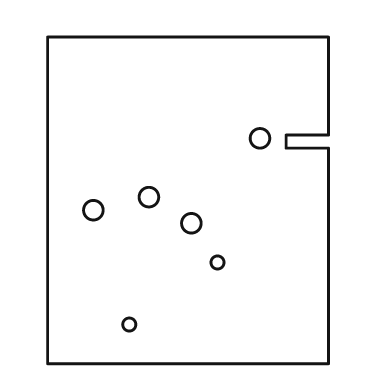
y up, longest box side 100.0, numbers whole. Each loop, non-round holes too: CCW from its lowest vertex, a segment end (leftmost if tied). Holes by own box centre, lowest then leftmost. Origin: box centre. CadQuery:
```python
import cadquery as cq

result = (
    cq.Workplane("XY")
    .moveTo(-43.0, -50.0)
    .lineTo(43.0, -50.0)
    .lineTo(43.0, 16.0)
    .lineTo(30.0, 16.0)
    .lineTo(30.0, 20.0)
    .lineTo(43.0, 20.0)
    .lineTo(43.0, 50.0)
    .lineTo(-43.0, 50.0)
    .close()
    .moveTo(-18.0, -38.0)
    .circle(2.0)
    .moveTo(9.0, -19.0)
    .circle(2.0)
    .moveTo(1.0, -7.0)
    .circle(3.0)
    .moveTo(-29.0, -3.0)
    .circle(3.0)
    .moveTo(-12.0, 1.0)
    .circle(3.0)
    .moveTo(22.0, 19.0)
    .circle(3.0)
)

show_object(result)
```